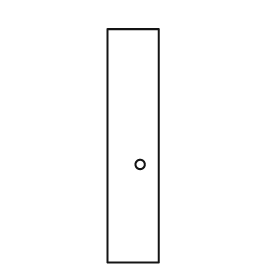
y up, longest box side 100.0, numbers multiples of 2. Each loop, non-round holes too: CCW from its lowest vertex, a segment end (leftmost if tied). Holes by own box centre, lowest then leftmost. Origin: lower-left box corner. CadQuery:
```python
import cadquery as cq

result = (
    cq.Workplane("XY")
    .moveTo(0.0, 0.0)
    .lineTo(22.0, 0.0)
    .lineTo(22.0, 100.0)
    .lineTo(0.0, 100.0)
    .close()
    .moveTo(14.0, 42.0)
    .circle(2.0)
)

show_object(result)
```